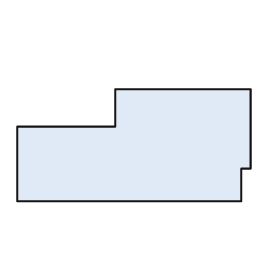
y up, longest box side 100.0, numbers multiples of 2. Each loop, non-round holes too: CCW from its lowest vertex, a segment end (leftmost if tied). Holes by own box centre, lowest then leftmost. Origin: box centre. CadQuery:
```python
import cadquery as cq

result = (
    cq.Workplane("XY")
    .moveTo(-50.0, -24.0)
    .lineTo(46.0, -24.0)
    .lineTo(46.0, -10.0)
    .lineTo(50.0, -10.0)
    .lineTo(50.0, 24.0)
    .lineTo(-8.0, 24.0)
    .lineTo(-8.0, 8.0)
    .lineTo(-50.0, 8.0)
    .close()
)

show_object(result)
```